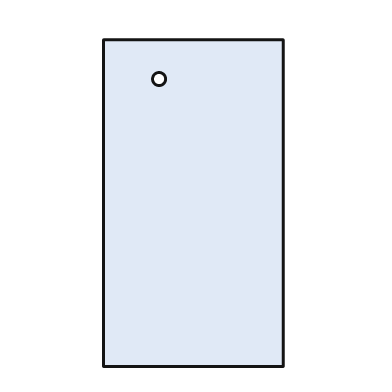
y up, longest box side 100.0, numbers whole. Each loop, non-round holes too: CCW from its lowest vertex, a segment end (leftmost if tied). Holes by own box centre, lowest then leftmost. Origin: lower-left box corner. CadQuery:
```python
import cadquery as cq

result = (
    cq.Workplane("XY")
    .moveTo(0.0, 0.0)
    .lineTo(55.0, 0.0)
    .lineTo(55.0, 100.0)
    .lineTo(0.0, 100.0)
    .close()
    .moveTo(17.0, 88.0)
    .circle(2.0)
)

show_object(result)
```